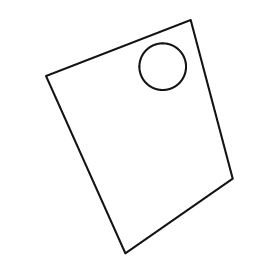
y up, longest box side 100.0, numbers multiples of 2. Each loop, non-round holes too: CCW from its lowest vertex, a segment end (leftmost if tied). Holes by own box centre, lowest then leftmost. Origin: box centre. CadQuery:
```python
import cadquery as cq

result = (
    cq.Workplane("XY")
    .moveTo(-6.0, -50.0)
    .lineTo(40.0, -18.0)
    .lineTo(22.0, 50.0)
    .lineTo(-40.0, 26.0)
    .close()
    .moveTo(10.0, 30.0)
    .circle(10.0)
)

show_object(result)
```